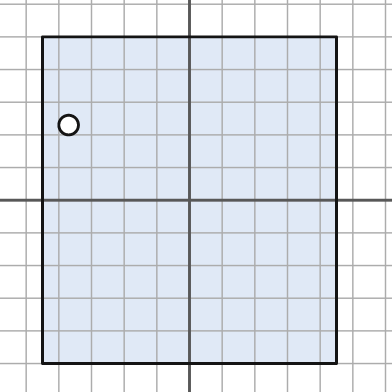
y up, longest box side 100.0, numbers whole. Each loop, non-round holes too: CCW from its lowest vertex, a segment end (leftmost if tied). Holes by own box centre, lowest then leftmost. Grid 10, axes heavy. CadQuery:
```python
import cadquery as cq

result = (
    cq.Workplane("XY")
    .moveTo(-45.0, -50.0)
    .lineTo(45.0, -50.0)
    .lineTo(45.0, 50.0)
    .lineTo(-45.0, 50.0)
    .close()
    .moveTo(-37.0, 23.0)
    .circle(3.0)
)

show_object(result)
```